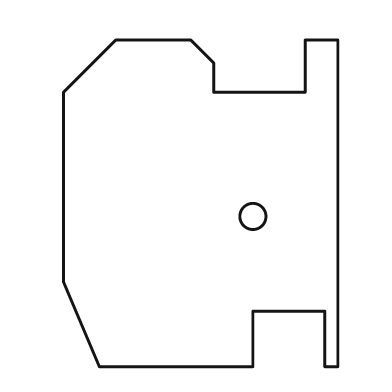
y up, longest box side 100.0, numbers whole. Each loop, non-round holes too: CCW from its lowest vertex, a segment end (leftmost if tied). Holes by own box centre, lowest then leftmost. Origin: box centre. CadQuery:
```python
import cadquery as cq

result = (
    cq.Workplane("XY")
    .moveTo(-31.0, -50.0)
    .lineTo(16.0, -50.0)
    .lineTo(16.0, -33.0)
    .lineTo(38.0, -33.0)
    .lineTo(38.0, -50.0)
    .lineTo(42.0, -50.0)
    .lineTo(42.0, 50.0)
    .lineTo(32.0, 50.0)
    .lineTo(32.0, 34.0)
    .lineTo(4.0, 34.0)
    .lineTo(4.0, 43.0)
    .lineTo(-3.0, 50.0)
    .lineTo(-26.0, 50.0)
    .lineTo(-42.0, 34.0)
    .lineTo(-42.0, -24.0)
    .close()
    .moveTo(16.0, -4.0)
    .circle(4.0)
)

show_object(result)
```